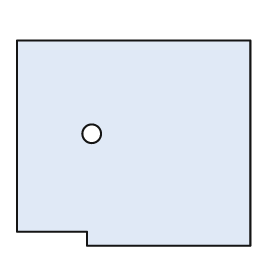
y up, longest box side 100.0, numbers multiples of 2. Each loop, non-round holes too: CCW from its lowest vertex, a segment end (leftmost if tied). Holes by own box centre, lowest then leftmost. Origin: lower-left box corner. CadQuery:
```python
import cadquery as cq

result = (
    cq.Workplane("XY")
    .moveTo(30.0, 0.0)
    .lineTo(100.0, 0.0)
    .lineTo(100.0, 88.0)
    .lineTo(0.0, 88.0)
    .lineTo(0.0, 6.0)
    .lineTo(30.0, 6.0)
    .close()
    .moveTo(32.0, 48.0)
    .circle(4.0)
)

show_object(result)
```